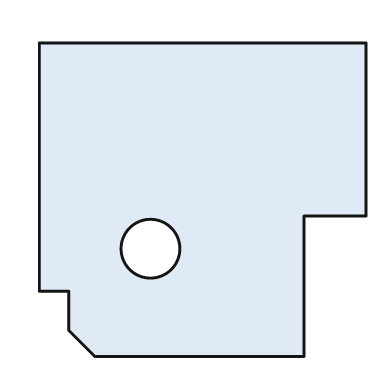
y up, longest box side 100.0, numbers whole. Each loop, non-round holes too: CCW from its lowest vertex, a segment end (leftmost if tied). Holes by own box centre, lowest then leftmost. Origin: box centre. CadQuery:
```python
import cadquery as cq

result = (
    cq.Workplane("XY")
    .moveTo(-33.0, -48.0)
    .lineTo(31.0, -48.0)
    .lineTo(31.0, -5.0)
    .lineTo(50.0, -5.0)
    .lineTo(50.0, 48.0)
    .lineTo(-50.0, 48.0)
    .lineTo(-50.0, -28.0)
    .lineTo(-41.0, -28.0)
    .lineTo(-41.0, -40.0)
    .close()
    .moveTo(-16.0, -15.0)
    .circle(9.0)
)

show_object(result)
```